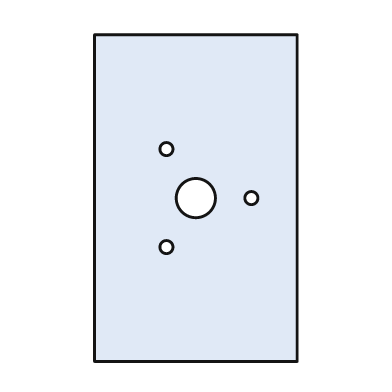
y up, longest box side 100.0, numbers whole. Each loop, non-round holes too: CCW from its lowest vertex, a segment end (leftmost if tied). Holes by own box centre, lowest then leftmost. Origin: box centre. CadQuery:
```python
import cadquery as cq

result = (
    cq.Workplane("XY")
    .moveTo(-31.0, -50.0)
    .lineTo(31.0, -50.0)
    .lineTo(31.0, 50.0)
    .lineTo(-31.0, 50.0)
    .close()
    .moveTo(-9.0, -15.0)
    .circle(2.0)
    .moveTo(0.0, 0.0)
    .circle(6.0)
    .moveTo(17.0, 0.0)
    .circle(2.0)
    .moveTo(-9.0, 15.0)
    .circle(2.0)
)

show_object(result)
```